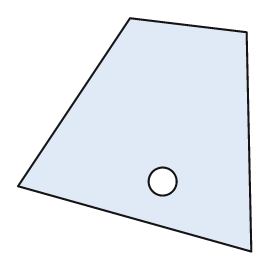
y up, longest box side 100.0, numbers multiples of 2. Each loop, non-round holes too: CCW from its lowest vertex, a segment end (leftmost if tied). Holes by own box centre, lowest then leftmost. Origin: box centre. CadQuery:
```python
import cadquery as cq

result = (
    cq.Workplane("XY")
    .moveTo(50.0, -50.0)
    .lineTo(48.0, 44.0)
    .lineTo(-2.0, 50.0)
    .lineTo(-50.0, -22.0)
    .close()
    .moveTo(12.0, -20.0)
    .circle(6.0)
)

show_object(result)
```